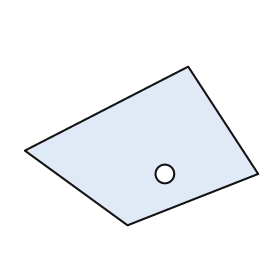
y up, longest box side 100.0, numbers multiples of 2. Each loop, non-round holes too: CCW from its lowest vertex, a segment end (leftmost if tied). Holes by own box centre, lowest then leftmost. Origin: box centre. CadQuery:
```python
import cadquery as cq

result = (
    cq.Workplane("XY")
    .moveTo(-6.0, -34.0)
    .lineTo(50.0, -12.0)
    .lineTo(20.0, 34.0)
    .lineTo(-50.0, -2.0)
    .close()
    .moveTo(10.0, -12.0)
    .circle(4.0)
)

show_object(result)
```